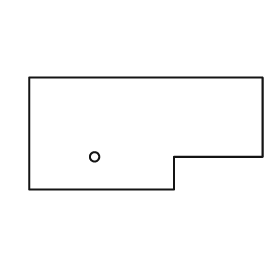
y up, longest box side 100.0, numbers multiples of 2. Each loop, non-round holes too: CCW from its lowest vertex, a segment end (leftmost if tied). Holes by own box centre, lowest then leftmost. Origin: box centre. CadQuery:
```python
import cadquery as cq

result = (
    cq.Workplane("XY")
    .moveTo(-50.0, -24.0)
    .lineTo(12.0, -24.0)
    .lineTo(12.0, -10.0)
    .lineTo(50.0, -10.0)
    .lineTo(50.0, 24.0)
    .lineTo(-50.0, 24.0)
    .close()
    .moveTo(-22.0, -10.0)
    .circle(2.0)
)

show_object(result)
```